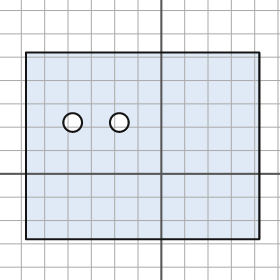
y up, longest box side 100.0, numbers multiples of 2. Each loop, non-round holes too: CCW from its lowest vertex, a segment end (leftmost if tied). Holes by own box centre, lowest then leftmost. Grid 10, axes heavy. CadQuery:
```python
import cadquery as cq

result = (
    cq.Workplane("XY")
    .moveTo(-58.0, -28.0)
    .lineTo(42.0, -28.0)
    .lineTo(42.0, 52.0)
    .lineTo(-58.0, 52.0)
    .close()
    .moveTo(-38.0, 22.0)
    .circle(4.0)
    .moveTo(-18.0, 22.0)
    .circle(4.0)
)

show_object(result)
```